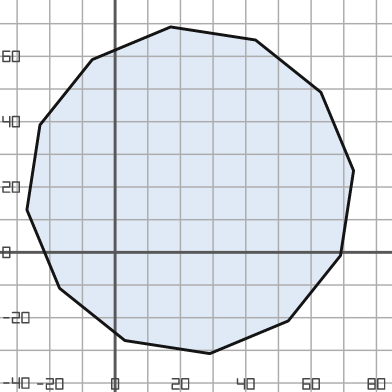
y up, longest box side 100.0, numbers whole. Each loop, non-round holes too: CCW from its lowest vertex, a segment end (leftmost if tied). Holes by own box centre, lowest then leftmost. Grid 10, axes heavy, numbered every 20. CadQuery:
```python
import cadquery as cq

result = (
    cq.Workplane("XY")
    .moveTo(29.0, -31.0)
    .lineTo(53.0, -21.0)
    .lineTo(69.0, -1.0)
    .lineTo(73.0, 25.0)
    .lineTo(63.0, 49.0)
    .lineTo(43.0, 65.0)
    .lineTo(17.0, 69.0)
    .lineTo(-7.0, 59.0)
    .lineTo(-23.0, 39.0)
    .lineTo(-27.0, 13.0)
    .lineTo(-17.0, -11.0)
    .lineTo(3.0, -27.0)
    .close()
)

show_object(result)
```